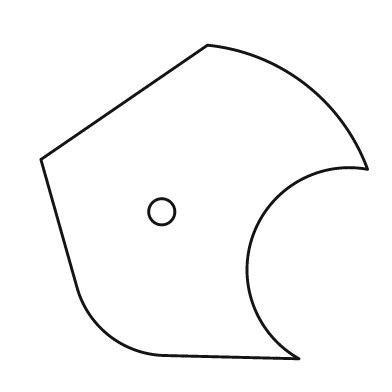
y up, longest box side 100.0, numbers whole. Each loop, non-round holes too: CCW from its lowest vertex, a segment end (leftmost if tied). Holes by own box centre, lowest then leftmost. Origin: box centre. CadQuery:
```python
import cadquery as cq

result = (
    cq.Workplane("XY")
    .moveTo(29.0, -48.0)
    .threePointArc((15.0, -10.0), (50.0, 10.0))
    .threePointArc((31.0, 36.0), (1.0, 48.0))
    .lineTo(-50.0, 13.0)
    .lineTo(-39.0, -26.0)
    .threePointArc((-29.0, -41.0), (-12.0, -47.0))
    .close()
    .moveTo(-13.0, -3.0)
    .circle(4.0)
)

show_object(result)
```